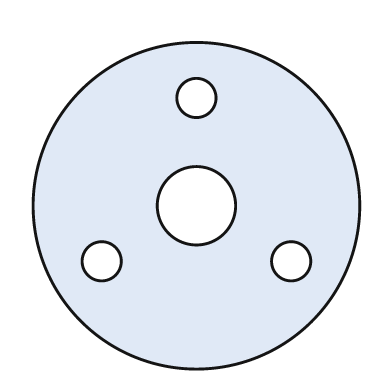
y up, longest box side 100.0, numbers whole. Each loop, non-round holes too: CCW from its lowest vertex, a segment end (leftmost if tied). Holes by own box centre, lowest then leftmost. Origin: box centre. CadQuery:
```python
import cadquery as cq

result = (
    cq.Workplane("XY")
    .moveTo(0.0, 0.0)
    .circle(50.0)
    .moveTo(-29.0, -17.0)
    .circle(6.0)
    .moveTo(29.0, -17.0)
    .circle(6.0)
    .moveTo(0.0, 0.0)
    .circle(12.0)
    .moveTo(0.0, 33.0)
    .circle(6.0)
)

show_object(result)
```